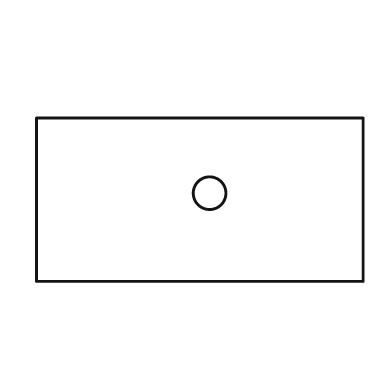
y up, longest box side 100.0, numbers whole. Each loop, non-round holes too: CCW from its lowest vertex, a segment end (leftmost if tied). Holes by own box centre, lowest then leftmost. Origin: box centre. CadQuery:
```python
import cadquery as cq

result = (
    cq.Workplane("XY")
    .moveTo(-50.0, -25.0)
    .lineTo(50.0, -25.0)
    .lineTo(50.0, 25.0)
    .lineTo(-50.0, 25.0)
    .close()
    .moveTo(3.0, 2.0)
    .circle(5.0)
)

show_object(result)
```